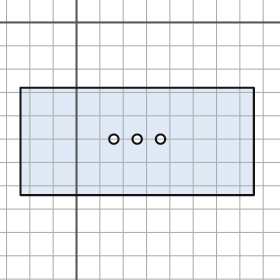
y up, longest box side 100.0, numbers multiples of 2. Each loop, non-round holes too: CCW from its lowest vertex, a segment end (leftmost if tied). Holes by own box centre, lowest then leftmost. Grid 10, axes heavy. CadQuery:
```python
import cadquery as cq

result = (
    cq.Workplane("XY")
    .moveTo(-24.0, -74.0)
    .lineTo(76.0, -74.0)
    .lineTo(76.0, -28.0)
    .lineTo(-24.0, -28.0)
    .close()
    .moveTo(16.0, -50.0)
    .circle(2.0)
    .moveTo(26.0, -50.0)
    .circle(2.0)
    .moveTo(36.0, -50.0)
    .circle(2.0)
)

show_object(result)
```